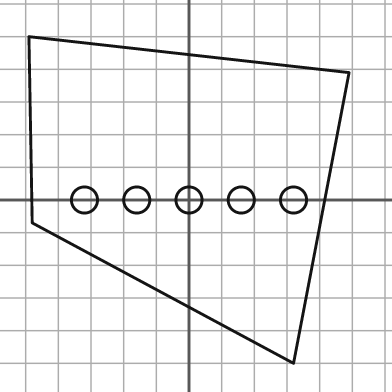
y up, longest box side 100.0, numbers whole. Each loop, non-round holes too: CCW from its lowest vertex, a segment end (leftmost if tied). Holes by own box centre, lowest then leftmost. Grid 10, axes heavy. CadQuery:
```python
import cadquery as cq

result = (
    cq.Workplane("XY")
    .moveTo(32.0, -50.0)
    .lineTo(49.0, 39.0)
    .lineTo(-49.0, 50.0)
    .lineTo(-48.0, -7.0)
    .close()
    .moveTo(-32.0, 0.0)
    .circle(4.0)
    .moveTo(-16.0, 0.0)
    .circle(4.0)
    .moveTo(0.0, 0.0)
    .circle(4.0)
    .moveTo(16.0, 0.0)
    .circle(4.0)
    .moveTo(32.0, 0.0)
    .circle(4.0)
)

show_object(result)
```